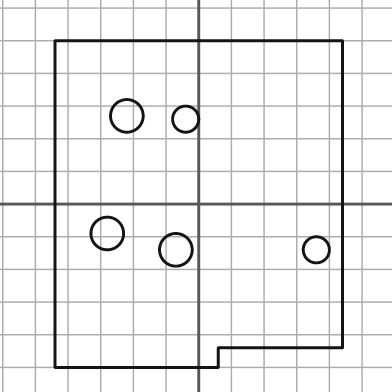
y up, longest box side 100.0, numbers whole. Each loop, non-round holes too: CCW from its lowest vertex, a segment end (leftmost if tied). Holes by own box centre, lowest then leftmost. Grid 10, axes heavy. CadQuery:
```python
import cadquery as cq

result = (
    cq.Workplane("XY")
    .moveTo(-44.0, -50.0)
    .lineTo(6.0, -50.0)
    .lineTo(6.0, -44.0)
    .lineTo(44.0, -44.0)
    .lineTo(44.0, 50.0)
    .lineTo(-44.0, 50.0)
    .close()
    .moveTo(-7.0, -14.0)
    .circle(5.0)
    .moveTo(36.0, -14.0)
    .circle(4.0)
    .moveTo(-28.0, -9.0)
    .circle(5.0)
    .moveTo(-4.0, 26.0)
    .circle(4.0)
    .moveTo(-22.0, 27.0)
    .circle(5.0)
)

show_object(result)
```